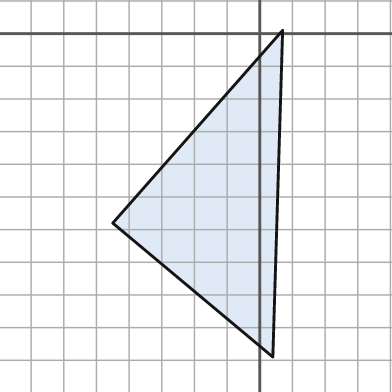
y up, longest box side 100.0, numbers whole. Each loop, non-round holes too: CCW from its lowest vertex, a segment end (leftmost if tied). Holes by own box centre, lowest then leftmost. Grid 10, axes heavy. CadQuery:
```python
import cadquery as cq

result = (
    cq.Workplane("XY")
    .moveTo(4.0, -99.0)
    .lineTo(7.0, 1.0)
    .lineTo(-45.0, -58.0)
    .close()
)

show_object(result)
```